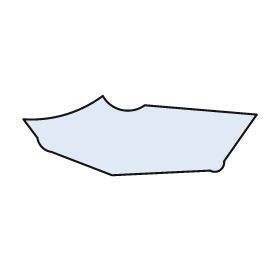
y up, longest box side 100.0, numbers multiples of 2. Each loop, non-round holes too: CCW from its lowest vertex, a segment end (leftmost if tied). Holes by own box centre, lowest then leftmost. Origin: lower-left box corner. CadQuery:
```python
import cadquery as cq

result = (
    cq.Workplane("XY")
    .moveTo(38.0, 0.0)
    .lineTo(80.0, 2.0)
    .threePointArc((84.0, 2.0), (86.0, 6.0))
    .lineTo(100.0, 26.0)
    .lineTo(52.0, 30.0)
    .threePointArc((42.0, 28.0), (34.0, 34.0))
    .threePointArc((18.0, 26.0), (0.0, 24.0))
    .lineTo(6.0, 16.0)
    .threePointArc((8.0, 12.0), (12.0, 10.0))
    .close()
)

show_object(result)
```